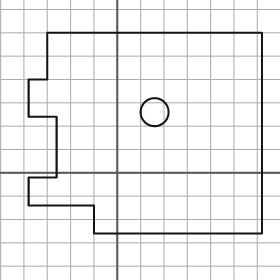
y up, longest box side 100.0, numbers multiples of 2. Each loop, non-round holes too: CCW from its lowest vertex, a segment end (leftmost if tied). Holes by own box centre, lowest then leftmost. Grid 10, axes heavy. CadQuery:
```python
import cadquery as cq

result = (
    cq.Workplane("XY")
    .moveTo(-10.0, -26.0)
    .lineTo(62.0, -26.0)
    .lineTo(62.0, 60.0)
    .lineTo(-30.0, 60.0)
    .lineTo(-30.0, 40.0)
    .lineTo(-38.0, 40.0)
    .lineTo(-38.0, 24.0)
    .lineTo(-26.0, 24.0)
    .lineTo(-26.0, -2.0)
    .lineTo(-38.0, -2.0)
    .lineTo(-38.0, -14.0)
    .lineTo(-10.0, -14.0)
    .close()
    .moveTo(16.0, 26.0)
    .circle(6.0)
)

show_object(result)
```